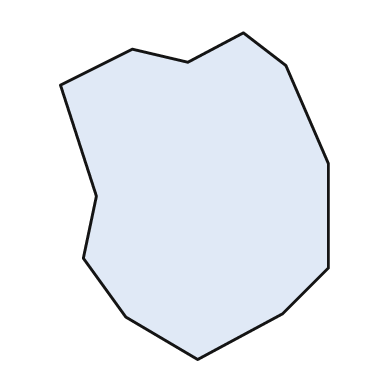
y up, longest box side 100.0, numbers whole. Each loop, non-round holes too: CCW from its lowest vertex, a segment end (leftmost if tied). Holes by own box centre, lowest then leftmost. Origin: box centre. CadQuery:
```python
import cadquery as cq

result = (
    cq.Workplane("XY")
    .moveTo(1.0, -50.0)
    .lineTo(27.0, -36.0)
    .lineTo(41.0, -22.0)
    .lineTo(41.0, 10.0)
    .lineTo(28.0, 40.0)
    .lineTo(15.0, 50.0)
    .lineTo(-2.0, 41.0)
    .lineTo(-19.0, 45.0)
    .lineTo(-41.0, 34.0)
    .lineTo(-30.0, 0.0)
    .lineTo(-34.0, -19.0)
    .lineTo(-21.0, -37.0)
    .close()
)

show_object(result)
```